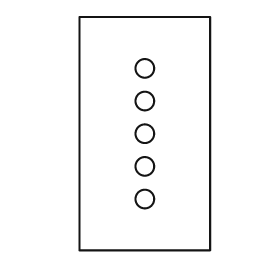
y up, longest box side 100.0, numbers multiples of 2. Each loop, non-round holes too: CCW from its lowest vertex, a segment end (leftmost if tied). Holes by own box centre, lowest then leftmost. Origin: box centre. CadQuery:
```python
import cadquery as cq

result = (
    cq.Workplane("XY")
    .moveTo(-28.0, -50.0)
    .lineTo(28.0, -50.0)
    .lineTo(28.0, 50.0)
    .lineTo(-28.0, 50.0)
    .close()
    .moveTo(0.0, -28.0)
    .circle(4.0)
    .moveTo(0.0, -14.0)
    .circle(4.0)
    .moveTo(0.0, 0.0)
    .circle(4.0)
    .moveTo(0.0, 14.0)
    .circle(4.0)
    .moveTo(0.0, 28.0)
    .circle(4.0)
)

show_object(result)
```